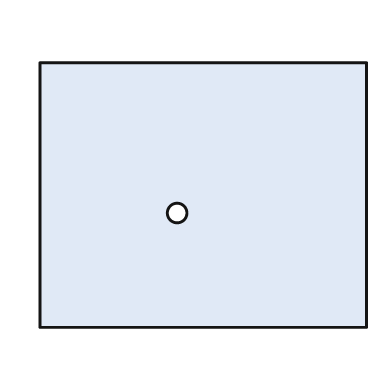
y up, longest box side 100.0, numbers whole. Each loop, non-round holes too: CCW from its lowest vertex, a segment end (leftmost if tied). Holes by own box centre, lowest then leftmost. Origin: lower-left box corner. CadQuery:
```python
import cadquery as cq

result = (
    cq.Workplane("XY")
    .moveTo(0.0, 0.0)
    .lineTo(100.0, 0.0)
    .lineTo(100.0, 81.0)
    .lineTo(0.0, 81.0)
    .close()
    .moveTo(42.0, 35.0)
    .circle(3.0)
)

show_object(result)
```